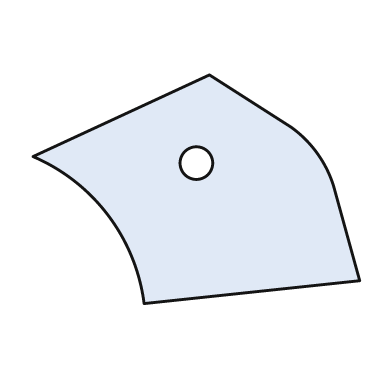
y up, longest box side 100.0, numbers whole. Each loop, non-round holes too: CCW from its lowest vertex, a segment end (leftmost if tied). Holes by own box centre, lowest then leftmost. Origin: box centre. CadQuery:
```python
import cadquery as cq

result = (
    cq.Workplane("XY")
    .moveTo(-16.0, -35.0)
    .lineTo(50.0, -28.0)
    .lineTo(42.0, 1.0)
    .threePointArc((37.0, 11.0), (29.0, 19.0))
    .lineTo(4.0, 35.0)
    .lineTo(-50.0, 10.0)
    .threePointArc((-27.0, -8.0), (-16.0, -35.0))
    .close()
    .moveTo(0.0, 8.0)
    .circle(5.0)
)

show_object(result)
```